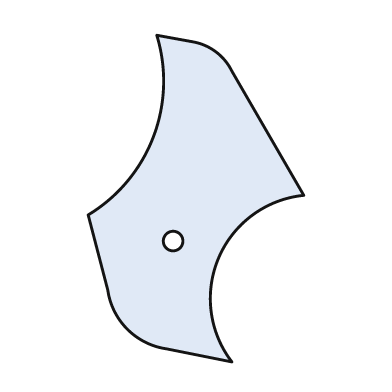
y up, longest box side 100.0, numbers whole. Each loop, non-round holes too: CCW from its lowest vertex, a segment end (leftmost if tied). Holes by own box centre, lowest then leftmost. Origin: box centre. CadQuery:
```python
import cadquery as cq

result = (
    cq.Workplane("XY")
    .moveTo(11.0, -50.0)
    .threePointArc((7.0, -18.0), (33.0, 1.0))
    .lineTo(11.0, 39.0)
    .threePointArc((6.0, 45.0), (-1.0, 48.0))
    .lineTo(-12.0, 50.0)
    .threePointArc((-13.0, 19.0), (-33.0, -5.0))
    .lineTo(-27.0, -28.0)
    .threePointArc((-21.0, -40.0), (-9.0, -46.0))
    .close()
    .moveTo(-7.0, -13.0)
    .circle(3.0)
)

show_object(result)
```